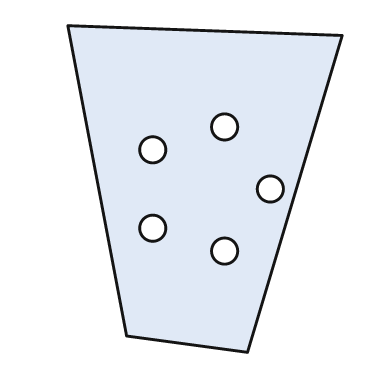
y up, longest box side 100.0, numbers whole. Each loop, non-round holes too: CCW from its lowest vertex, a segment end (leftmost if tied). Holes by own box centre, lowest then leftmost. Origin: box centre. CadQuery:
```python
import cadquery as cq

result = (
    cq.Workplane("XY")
    .moveTo(13.0, -50.0)
    .lineTo(42.0, 47.0)
    .lineTo(-42.0, 50.0)
    .lineTo(-24.0, -45.0)
    .close()
    .moveTo(6.0, -19.0)
    .circle(4.0)
    .moveTo(-16.0, -12.0)
    .circle(4.0)
    .moveTo(20.0, 0.0)
    .circle(4.0)
    .moveTo(-16.0, 12.0)
    .circle(4.0)
    .moveTo(6.0, 19.0)
    .circle(4.0)
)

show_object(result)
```